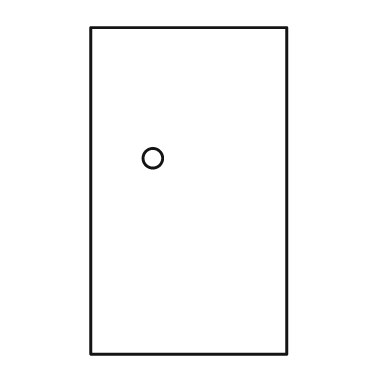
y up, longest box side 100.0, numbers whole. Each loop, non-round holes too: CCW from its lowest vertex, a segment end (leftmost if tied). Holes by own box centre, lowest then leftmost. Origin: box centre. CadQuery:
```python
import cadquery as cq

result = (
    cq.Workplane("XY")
    .moveTo(-30.0, -50.0)
    .lineTo(30.0, -50.0)
    .lineTo(30.0, 50.0)
    .lineTo(-30.0, 50.0)
    .close()
    .moveTo(-11.0, 10.0)
    .circle(3.0)
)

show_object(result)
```